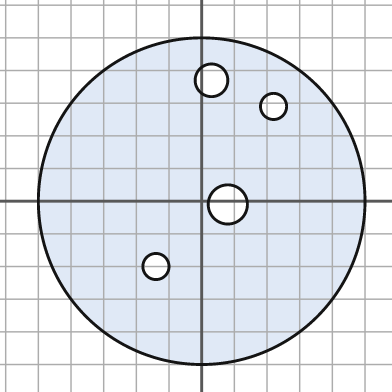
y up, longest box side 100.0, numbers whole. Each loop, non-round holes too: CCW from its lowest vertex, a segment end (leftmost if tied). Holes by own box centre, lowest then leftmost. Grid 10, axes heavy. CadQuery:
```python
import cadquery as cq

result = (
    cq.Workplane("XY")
    .moveTo(0.0, 0.0)
    .circle(50.0)
    .moveTo(-14.0, -20.0)
    .circle(4.0)
    .moveTo(8.0, -1.0)
    .circle(6.0)
    .moveTo(22.0, 29.0)
    .circle(4.0)
    .moveTo(3.0, 37.0)
    .circle(5.0)
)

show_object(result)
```